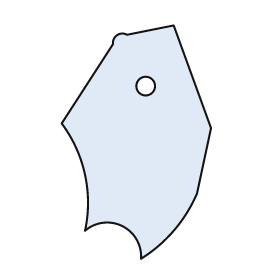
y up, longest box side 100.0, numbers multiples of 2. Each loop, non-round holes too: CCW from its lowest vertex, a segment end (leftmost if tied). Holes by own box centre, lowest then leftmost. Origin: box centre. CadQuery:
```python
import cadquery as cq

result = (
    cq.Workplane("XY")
    .moveTo(2.0, -50.0)
    .threePointArc((16.0, -38.0), (26.0, -22.0))
    .lineTo(32.0, 6.0)
    .lineTo(16.0, 50.0)
    .lineTo(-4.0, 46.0)
    .threePointArc((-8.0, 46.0), (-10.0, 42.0))
    .lineTo(-32.0, 8.0)
    .threePointArc((-22.0, -14.0), (-22.0, -38.0))
    .threePointArc((-6.0, -36.0), (2.0, -50.0))
    .close()
    .moveTo(4.0, 24.0)
    .circle(4.0)
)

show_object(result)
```